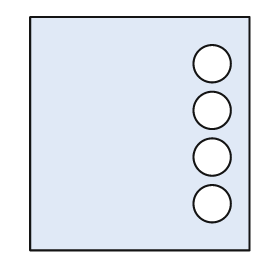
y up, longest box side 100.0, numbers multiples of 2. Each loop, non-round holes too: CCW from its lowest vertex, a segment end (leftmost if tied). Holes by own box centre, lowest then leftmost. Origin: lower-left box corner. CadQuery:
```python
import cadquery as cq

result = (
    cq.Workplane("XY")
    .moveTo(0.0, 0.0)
    .lineTo(94.0, 0.0)
    .lineTo(94.0, 100.0)
    .lineTo(0.0, 100.0)
    .close()
    .moveTo(78.0, 20.0)
    .circle(8.0)
    .moveTo(78.0, 40.0)
    .circle(8.0)
    .moveTo(78.0, 60.0)
    .circle(8.0)
    .moveTo(78.0, 80.0)
    .circle(8.0)
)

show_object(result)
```